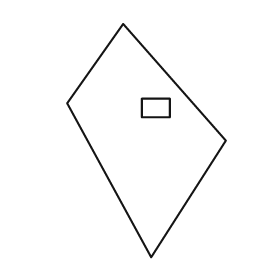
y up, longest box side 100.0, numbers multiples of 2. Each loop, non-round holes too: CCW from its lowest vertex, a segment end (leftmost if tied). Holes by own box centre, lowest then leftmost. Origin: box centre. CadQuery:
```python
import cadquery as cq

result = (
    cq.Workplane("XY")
    .moveTo(2.0, -50.0)
    .lineTo(34.0, 0.0)
    .lineTo(-10.0, 50.0)
    .lineTo(-34.0, 16.0)
    .close()
    .moveTo(-2.0, 10.0)
    .lineTo(10.0, 10.0)
    .lineTo(10.0, 18.0)
    .lineTo(-2.0, 18.0)
    .close()
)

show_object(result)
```